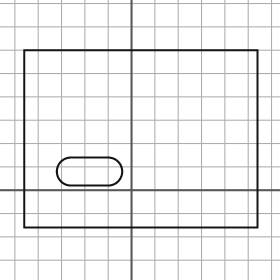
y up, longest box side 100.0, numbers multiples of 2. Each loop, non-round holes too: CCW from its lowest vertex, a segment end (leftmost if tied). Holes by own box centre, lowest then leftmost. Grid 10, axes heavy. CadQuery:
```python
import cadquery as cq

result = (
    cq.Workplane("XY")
    .moveTo(-46.0, -16.0)
    .lineTo(54.0, -16.0)
    .lineTo(54.0, 60.0)
    .lineTo(-46.0, 60.0)
    .close()
    .moveTo(-26.0, 2.0)
    .lineTo(-10.0, 2.0)
    .threePointArc((-4.0, 8.0), (-10.0, 14.0))
    .lineTo(-26.0, 14.0)
    .threePointArc((-32.0, 8.0), (-26.0, 2.0))
    .close()
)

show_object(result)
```